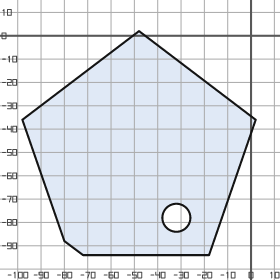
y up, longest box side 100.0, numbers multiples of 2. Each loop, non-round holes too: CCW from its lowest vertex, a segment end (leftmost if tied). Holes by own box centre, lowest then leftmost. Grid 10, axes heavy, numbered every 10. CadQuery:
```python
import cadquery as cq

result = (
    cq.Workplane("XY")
    .moveTo(-72.0, -94.0)
    .lineTo(-18.0, -94.0)
    .lineTo(2.0, -36.0)
    .lineTo(-48.0, 2.0)
    .lineTo(-98.0, -36.0)
    .lineTo(-80.0, -88.0)
    .close()
    .moveTo(-32.0, -78.0)
    .circle(6.0)
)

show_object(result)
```